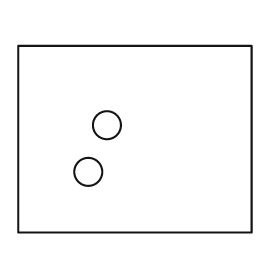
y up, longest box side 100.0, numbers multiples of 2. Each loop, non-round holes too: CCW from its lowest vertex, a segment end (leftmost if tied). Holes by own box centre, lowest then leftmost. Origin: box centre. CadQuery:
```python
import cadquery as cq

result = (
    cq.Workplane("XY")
    .moveTo(-50.0, -40.0)
    .lineTo(50.0, -40.0)
    .lineTo(50.0, 40.0)
    .lineTo(-50.0, 40.0)
    .close()
    .moveTo(-20.0, -14.0)
    .circle(6.0)
    .moveTo(-12.0, 6.0)
    .circle(6.0)
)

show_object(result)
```